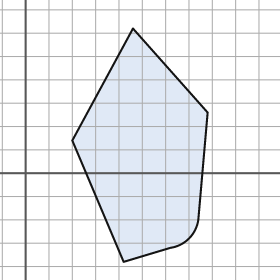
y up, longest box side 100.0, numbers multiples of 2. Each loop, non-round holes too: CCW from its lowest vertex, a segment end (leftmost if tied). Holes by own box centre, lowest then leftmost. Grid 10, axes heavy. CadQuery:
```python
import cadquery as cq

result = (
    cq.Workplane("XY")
    .moveTo(42.0, -38.0)
    .lineTo(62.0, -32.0)
    .threePointArc((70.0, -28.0), (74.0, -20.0))
    .lineTo(78.0, 26.0)
    .lineTo(46.0, 62.0)
    .lineTo(20.0, 14.0)
    .close()
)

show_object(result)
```